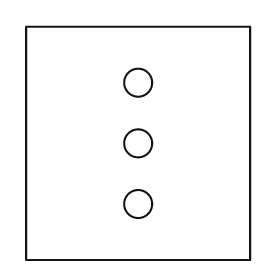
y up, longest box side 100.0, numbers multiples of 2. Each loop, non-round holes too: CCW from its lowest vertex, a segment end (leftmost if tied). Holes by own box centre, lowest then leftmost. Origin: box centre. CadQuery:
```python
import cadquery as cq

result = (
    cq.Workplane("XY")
    .moveTo(-48.0, -50.0)
    .lineTo(48.0, -50.0)
    .lineTo(48.0, 50.0)
    .lineTo(-48.0, 50.0)
    .close()
    .moveTo(0.0, -26.0)
    .circle(6.0)
    .moveTo(0.0, 0.0)
    .circle(6.0)
    .moveTo(0.0, 26.0)
    .circle(6.0)
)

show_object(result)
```